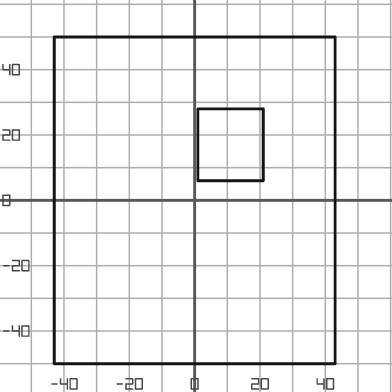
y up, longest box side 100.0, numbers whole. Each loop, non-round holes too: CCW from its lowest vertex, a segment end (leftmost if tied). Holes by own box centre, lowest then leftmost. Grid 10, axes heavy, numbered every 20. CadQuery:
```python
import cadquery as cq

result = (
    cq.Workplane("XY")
    .moveTo(-43.0, -50.0)
    .lineTo(43.0, -50.0)
    .lineTo(43.0, 50.0)
    .lineTo(-43.0, 50.0)
    .close()
    .moveTo(1.0, 6.0)
    .lineTo(21.0, 6.0)
    .lineTo(21.0, 28.0)
    .lineTo(1.0, 28.0)
    .close()
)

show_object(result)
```